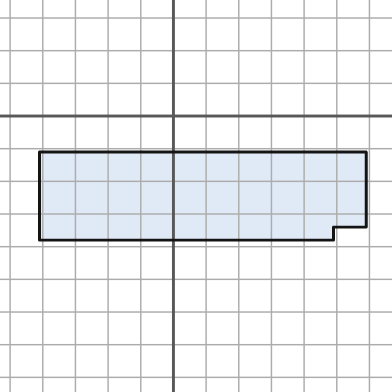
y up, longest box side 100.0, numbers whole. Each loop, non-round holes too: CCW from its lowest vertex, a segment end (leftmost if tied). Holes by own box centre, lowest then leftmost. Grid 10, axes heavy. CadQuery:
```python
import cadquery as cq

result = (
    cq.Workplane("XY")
    .moveTo(-41.0, -38.0)
    .lineTo(49.0, -38.0)
    .lineTo(49.0, -34.0)
    .lineTo(59.0, -34.0)
    .lineTo(59.0, -11.0)
    .lineTo(-41.0, -11.0)
    .close()
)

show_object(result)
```